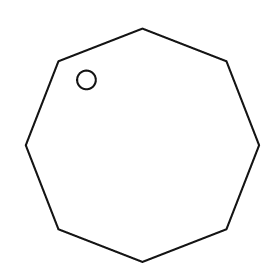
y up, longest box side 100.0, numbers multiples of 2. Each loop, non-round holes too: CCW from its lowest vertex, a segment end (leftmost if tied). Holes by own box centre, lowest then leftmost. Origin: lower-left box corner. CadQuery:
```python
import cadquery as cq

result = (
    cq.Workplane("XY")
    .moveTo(50.0, 0.0)
    .lineTo(86.0, 14.0)
    .lineTo(100.0, 50.0)
    .lineTo(86.0, 86.0)
    .lineTo(50.0, 100.0)
    .lineTo(14.0, 86.0)
    .lineTo(0.0, 50.0)
    .lineTo(14.0, 14.0)
    .close()
    .moveTo(26.0, 78.0)
    .circle(4.0)
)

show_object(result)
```